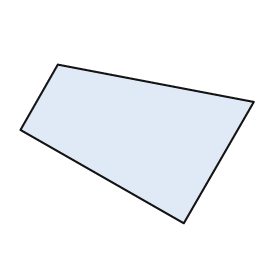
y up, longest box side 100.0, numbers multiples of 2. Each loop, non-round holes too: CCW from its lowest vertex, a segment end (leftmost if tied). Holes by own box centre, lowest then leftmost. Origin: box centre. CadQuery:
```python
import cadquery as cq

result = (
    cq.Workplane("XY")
    .moveTo(20.0, -34.0)
    .lineTo(50.0, 18.0)
    .lineTo(-34.0, 34.0)
    .lineTo(-50.0, 6.0)
    .close()
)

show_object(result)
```